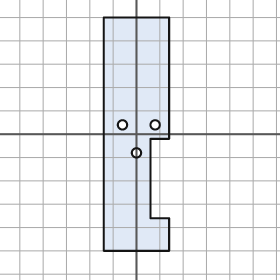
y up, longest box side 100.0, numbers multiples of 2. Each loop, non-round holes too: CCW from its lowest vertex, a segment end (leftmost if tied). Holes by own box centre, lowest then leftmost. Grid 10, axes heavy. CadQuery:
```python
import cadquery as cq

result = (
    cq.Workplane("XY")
    .moveTo(-14.0, -50.0)
    .lineTo(14.0, -50.0)
    .lineTo(14.0, -36.0)
    .lineTo(6.0, -36.0)
    .lineTo(6.0, -2.0)
    .lineTo(14.0, -2.0)
    .lineTo(14.0, 50.0)
    .lineTo(-14.0, 50.0)
    .close()
    .moveTo(0.0, -8.0)
    .circle(2.0)
    .moveTo(-6.0, 4.0)
    .circle(2.0)
    .moveTo(8.0, 4.0)
    .circle(2.0)
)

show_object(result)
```